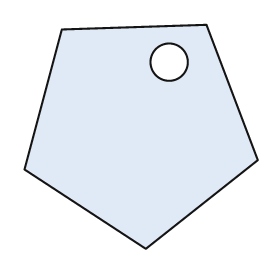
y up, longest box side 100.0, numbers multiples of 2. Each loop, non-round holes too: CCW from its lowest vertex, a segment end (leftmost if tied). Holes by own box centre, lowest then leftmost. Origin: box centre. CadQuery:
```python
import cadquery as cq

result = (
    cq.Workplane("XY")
    .moveTo(2.0, -48.0)
    .lineTo(50.0, -10.0)
    .lineTo(28.0, 48.0)
    .lineTo(-34.0, 46.0)
    .lineTo(-50.0, -14.0)
    .close()
    .moveTo(12.0, 32.0)
    .circle(8.0)
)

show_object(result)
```